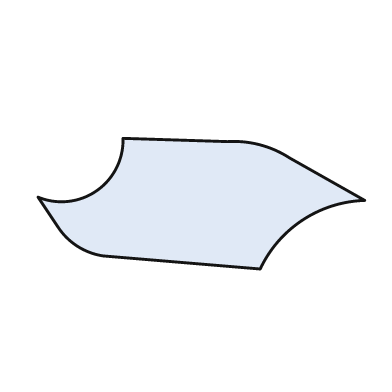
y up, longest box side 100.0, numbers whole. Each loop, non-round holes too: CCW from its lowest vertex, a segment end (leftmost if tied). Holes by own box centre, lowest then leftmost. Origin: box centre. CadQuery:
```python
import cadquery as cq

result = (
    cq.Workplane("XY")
    .moveTo(18.0, -20.0)
    .threePointArc((31.0, -5.0), (50.0, 1.0))
    .lineTo(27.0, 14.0)
    .threePointArc((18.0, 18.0), (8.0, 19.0))
    .lineTo(-24.0, 20.0)
    .threePointArc((-32.0, 4.0), (-50.0, 2.0))
    .lineTo(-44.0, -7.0)
    .threePointArc((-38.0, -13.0), (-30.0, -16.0))
    .close()
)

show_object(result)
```